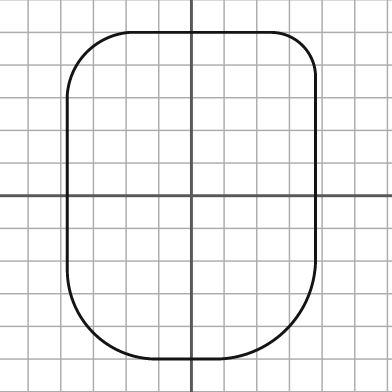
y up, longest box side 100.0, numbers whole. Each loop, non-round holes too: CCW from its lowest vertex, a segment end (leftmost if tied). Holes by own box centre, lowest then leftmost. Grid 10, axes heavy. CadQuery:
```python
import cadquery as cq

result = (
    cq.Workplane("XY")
    .moveTo(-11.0, -50.0)
    .lineTo(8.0, -50.0)
    .threePointArc((29.0, -41.0), (38.0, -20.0))
    .lineTo(38.0, 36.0)
    .threePointArc((34.0, 46.0), (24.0, 50.0))
    .lineTo(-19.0, 50.0)
    .threePointArc((-32.0, 44.0), (-38.0, 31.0))
    .lineTo(-38.0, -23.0)
    .threePointArc((-30.0, -42.0), (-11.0, -50.0))
    .close()
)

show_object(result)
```